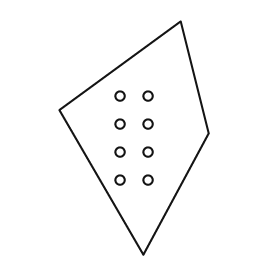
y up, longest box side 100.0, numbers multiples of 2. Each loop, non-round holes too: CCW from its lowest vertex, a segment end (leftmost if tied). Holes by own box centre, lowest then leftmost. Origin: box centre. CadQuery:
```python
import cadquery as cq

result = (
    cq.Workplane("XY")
    .moveTo(4.0, -50.0)
    .lineTo(32.0, 2.0)
    .lineTo(20.0, 50.0)
    .lineTo(-32.0, 12.0)
    .close()
    .moveTo(-6.0, -18.0)
    .circle(2.0)
    .moveTo(6.0, -18.0)
    .circle(2.0)
    .moveTo(-6.0, -6.0)
    .circle(2.0)
    .moveTo(6.0, -6.0)
    .circle(2.0)
    .moveTo(-6.0, 6.0)
    .circle(2.0)
    .moveTo(6.0, 6.0)
    .circle(2.0)
    .moveTo(-6.0, 18.0)
    .circle(2.0)
    .moveTo(6.0, 18.0)
    .circle(2.0)
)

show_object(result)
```